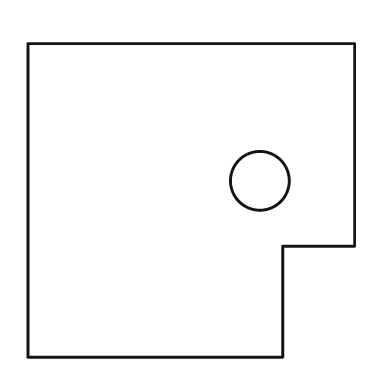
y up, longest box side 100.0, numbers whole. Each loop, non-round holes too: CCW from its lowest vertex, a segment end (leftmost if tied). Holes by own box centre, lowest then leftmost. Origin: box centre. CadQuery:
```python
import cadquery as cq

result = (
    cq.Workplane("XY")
    .moveTo(-50.0, -48.0)
    .lineTo(28.0, -48.0)
    .lineTo(28.0, -14.0)
    .lineTo(50.0, -14.0)
    .lineTo(50.0, 48.0)
    .lineTo(-50.0, 48.0)
    .close()
    .moveTo(21.0, 6.0)
    .circle(9.0)
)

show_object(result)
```